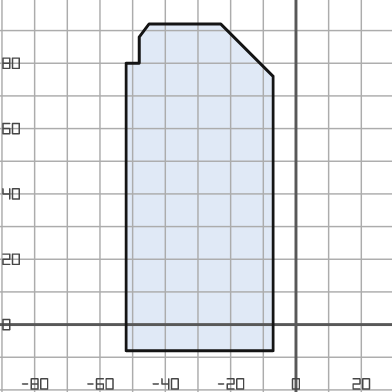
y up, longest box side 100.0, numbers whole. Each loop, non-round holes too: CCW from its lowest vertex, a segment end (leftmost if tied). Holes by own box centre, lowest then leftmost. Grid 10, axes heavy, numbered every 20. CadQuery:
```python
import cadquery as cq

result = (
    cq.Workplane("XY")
    .moveTo(-52.0, -8.0)
    .lineTo(-7.0, -8.0)
    .lineTo(-7.0, 76.0)
    .lineTo(-23.0, 92.0)
    .lineTo(-45.0, 92.0)
    .lineTo(-48.0, 88.0)
    .lineTo(-48.0, 80.0)
    .lineTo(-52.0, 80.0)
    .close()
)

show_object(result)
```